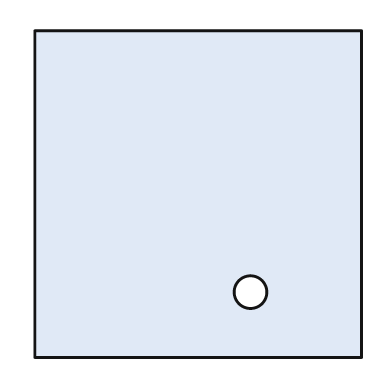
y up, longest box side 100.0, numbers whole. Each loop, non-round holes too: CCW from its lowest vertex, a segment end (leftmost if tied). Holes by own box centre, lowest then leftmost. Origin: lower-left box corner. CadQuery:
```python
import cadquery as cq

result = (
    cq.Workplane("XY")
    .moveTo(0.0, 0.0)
    .lineTo(100.0, 0.0)
    .lineTo(100.0, 100.0)
    .lineTo(0.0, 100.0)
    .close()
    .moveTo(66.0, 20.0)
    .circle(5.0)
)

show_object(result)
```